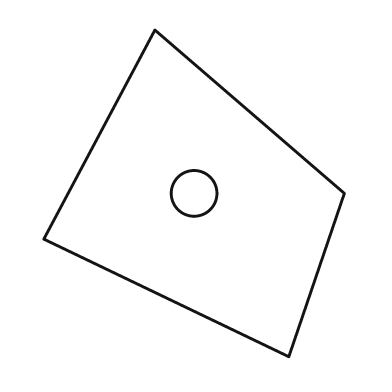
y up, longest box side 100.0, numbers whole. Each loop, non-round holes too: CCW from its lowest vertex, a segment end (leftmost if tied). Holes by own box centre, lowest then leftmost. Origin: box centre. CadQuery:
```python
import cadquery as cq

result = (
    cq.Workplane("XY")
    .moveTo(29.0, -50.0)
    .lineTo(46.0, 0.0)
    .lineTo(-12.0, 50.0)
    .lineTo(-46.0, -14.0)
    .close()
    .moveTo(0.0, 0.0)
    .circle(7.0)
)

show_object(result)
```